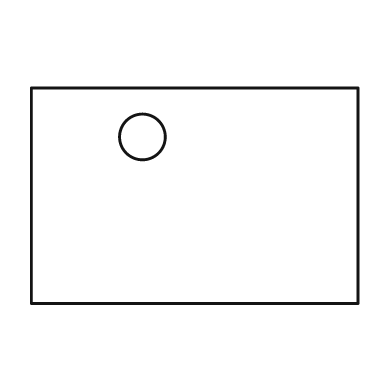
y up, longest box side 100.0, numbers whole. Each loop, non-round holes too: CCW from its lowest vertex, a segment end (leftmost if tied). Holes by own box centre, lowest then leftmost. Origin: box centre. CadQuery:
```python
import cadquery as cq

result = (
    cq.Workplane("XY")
    .moveTo(-50.0, -33.0)
    .lineTo(50.0, -33.0)
    .lineTo(50.0, 33.0)
    .lineTo(-50.0, 33.0)
    .close()
    .moveTo(-16.0, 18.0)
    .circle(7.0)
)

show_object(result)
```